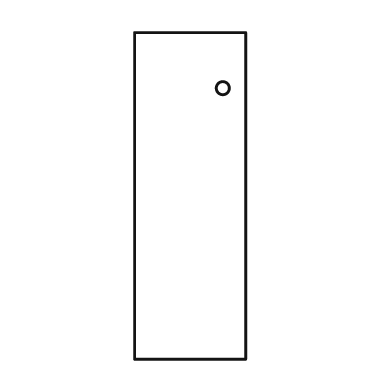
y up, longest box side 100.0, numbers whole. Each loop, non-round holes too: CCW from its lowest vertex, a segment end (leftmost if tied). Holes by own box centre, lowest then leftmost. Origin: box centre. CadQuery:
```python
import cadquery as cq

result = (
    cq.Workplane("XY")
    .moveTo(-17.0, -50.0)
    .lineTo(17.0, -50.0)
    .lineTo(17.0, 50.0)
    .lineTo(-17.0, 50.0)
    .close()
    .moveTo(10.0, 33.0)
    .circle(2.0)
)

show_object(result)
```